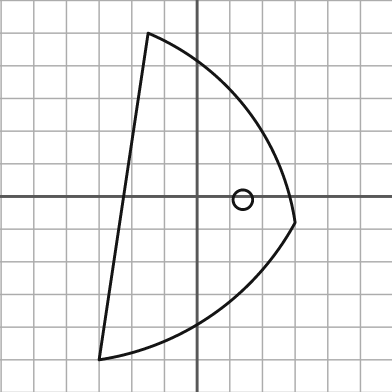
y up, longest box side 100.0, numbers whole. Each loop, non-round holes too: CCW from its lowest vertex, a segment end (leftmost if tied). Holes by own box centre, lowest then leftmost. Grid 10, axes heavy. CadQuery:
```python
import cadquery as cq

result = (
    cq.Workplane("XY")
    .moveTo(-30.0, -50.0)
    .threePointArc((5.0, -36.0), (30.0, -8.0))
    .threePointArc((15.0, 27.0), (-15.0, 50.0))
    .close()
    .moveTo(14.0, -1.0)
    .circle(3.0)
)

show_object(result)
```